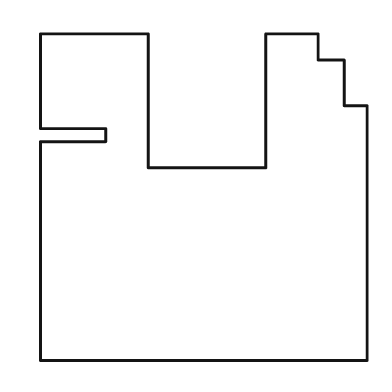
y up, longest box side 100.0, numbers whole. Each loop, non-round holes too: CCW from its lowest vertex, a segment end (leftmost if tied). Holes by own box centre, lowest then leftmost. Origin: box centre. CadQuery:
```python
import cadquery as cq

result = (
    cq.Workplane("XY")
    .moveTo(-50.0, -50.0)
    .lineTo(50.0, -50.0)
    .lineTo(50.0, 28.0)
    .lineTo(43.0, 28.0)
    .lineTo(43.0, 42.0)
    .lineTo(35.0, 42.0)
    .lineTo(35.0, 50.0)
    .lineTo(19.0, 50.0)
    .lineTo(19.0, 9.0)
    .lineTo(-17.0, 9.0)
    .lineTo(-17.0, 50.0)
    .lineTo(-50.0, 50.0)
    .lineTo(-50.0, 21.0)
    .lineTo(-30.0, 21.0)
    .lineTo(-30.0, 17.0)
    .lineTo(-50.0, 17.0)
    .close()
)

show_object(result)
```